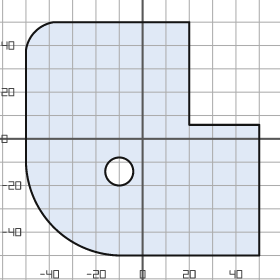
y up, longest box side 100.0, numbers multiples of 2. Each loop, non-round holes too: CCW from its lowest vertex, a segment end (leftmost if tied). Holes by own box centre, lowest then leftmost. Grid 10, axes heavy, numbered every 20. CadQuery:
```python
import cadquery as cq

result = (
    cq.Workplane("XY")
    .moveTo(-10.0, -50.0)
    .lineTo(50.0, -50.0)
    .lineTo(50.0, 6.0)
    .lineTo(20.0, 6.0)
    .lineTo(20.0, 50.0)
    .lineTo(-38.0, 50.0)
    .threePointArc((-46.0, 46.0), (-50.0, 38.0))
    .lineTo(-50.0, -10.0)
    .threePointArc((-38.0, -38.0), (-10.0, -50.0))
    .close()
    .moveTo(-10.0, -14.0)
    .circle(6.0)
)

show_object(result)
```